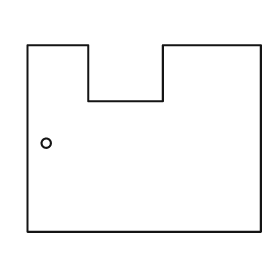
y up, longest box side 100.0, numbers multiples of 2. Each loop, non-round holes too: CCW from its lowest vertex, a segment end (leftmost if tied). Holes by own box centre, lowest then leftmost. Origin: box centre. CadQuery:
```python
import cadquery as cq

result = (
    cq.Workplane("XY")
    .moveTo(-50.0, -40.0)
    .lineTo(50.0, -40.0)
    .lineTo(50.0, 40.0)
    .lineTo(8.0, 40.0)
    .lineTo(8.0, 16.0)
    .lineTo(-24.0, 16.0)
    .lineTo(-24.0, 40.0)
    .lineTo(-50.0, 40.0)
    .close()
    .moveTo(-42.0, -2.0)
    .circle(2.0)
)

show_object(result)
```